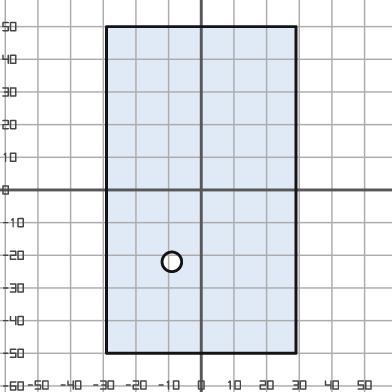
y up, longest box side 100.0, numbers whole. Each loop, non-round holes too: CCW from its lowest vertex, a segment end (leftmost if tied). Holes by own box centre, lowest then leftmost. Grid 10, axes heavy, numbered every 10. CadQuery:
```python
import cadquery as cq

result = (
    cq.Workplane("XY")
    .moveTo(-29.0, -50.0)
    .lineTo(29.0, -50.0)
    .lineTo(29.0, 50.0)
    .lineTo(-29.0, 50.0)
    .close()
    .moveTo(-9.0, -22.0)
    .circle(3.0)
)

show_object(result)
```